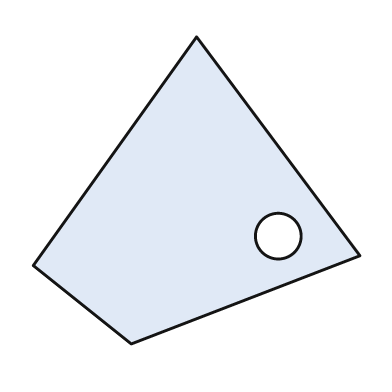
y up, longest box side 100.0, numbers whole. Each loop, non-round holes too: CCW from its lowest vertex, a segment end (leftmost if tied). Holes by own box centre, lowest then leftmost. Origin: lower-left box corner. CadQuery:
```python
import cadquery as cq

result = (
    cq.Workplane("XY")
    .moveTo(30.0, 0.0)
    .lineTo(100.0, 27.0)
    .lineTo(50.0, 94.0)
    .lineTo(0.0, 24.0)
    .close()
    .moveTo(75.0, 33.0)
    .circle(7.0)
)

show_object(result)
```